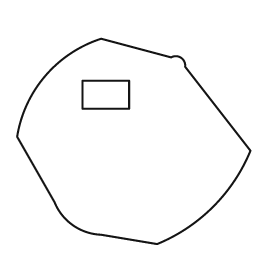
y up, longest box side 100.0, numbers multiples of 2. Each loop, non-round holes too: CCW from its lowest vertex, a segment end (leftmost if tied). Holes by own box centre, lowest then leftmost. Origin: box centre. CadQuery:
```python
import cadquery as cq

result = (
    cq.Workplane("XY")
    .moveTo(10.0, -44.0)
    .threePointArc((34.0, -28.0), (50.0, -4.0))
    .lineTo(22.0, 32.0)
    .threePointArc((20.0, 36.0), (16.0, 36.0))
    .lineTo(-14.0, 44.0)
    .threePointArc((-38.0, 28.0), (-50.0, 2.0))
    .lineTo(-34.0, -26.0)
    .threePointArc((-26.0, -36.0), (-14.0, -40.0))
    .close()
    .moveTo(-22.0, 14.0)
    .lineTo(-2.0, 14.0)
    .lineTo(-2.0, 26.0)
    .lineTo(-22.0, 26.0)
    .close()
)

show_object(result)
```